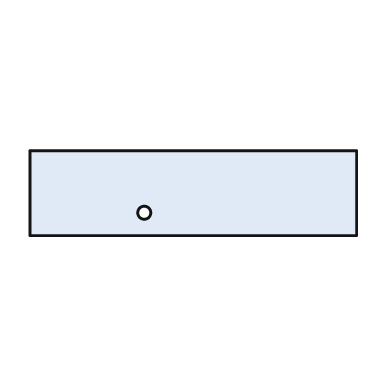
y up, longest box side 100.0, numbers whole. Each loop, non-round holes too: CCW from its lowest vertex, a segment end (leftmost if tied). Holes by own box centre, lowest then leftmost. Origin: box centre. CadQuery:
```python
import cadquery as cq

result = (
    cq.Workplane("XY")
    .moveTo(-50.0, -13.0)
    .lineTo(50.0, -13.0)
    .lineTo(50.0, 13.0)
    .lineTo(-50.0, 13.0)
    .close()
    .moveTo(-15.0, -6.0)
    .circle(2.0)
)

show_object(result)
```